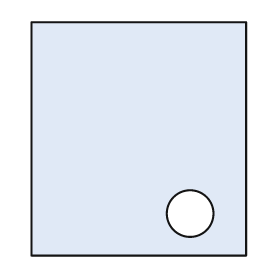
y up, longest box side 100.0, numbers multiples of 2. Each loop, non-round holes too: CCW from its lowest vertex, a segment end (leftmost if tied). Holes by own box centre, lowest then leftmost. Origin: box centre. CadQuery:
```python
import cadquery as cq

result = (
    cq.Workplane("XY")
    .moveTo(-46.0, -50.0)
    .lineTo(46.0, -50.0)
    .lineTo(46.0, 50.0)
    .lineTo(-46.0, 50.0)
    .close()
    .moveTo(22.0, -32.0)
    .circle(10.0)
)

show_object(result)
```